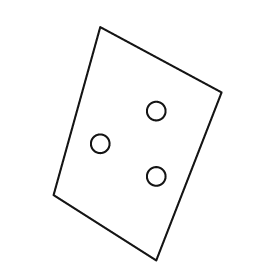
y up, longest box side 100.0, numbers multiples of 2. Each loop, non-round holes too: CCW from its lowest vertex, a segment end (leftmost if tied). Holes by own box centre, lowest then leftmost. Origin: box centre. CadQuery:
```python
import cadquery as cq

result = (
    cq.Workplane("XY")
    .moveTo(8.0, -50.0)
    .lineTo(36.0, 22.0)
    .lineTo(-16.0, 50.0)
    .lineTo(-36.0, -22.0)
    .close()
    .moveTo(8.0, -14.0)
    .circle(4.0)
    .moveTo(-16.0, 0.0)
    .circle(4.0)
    .moveTo(8.0, 14.0)
    .circle(4.0)
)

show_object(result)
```